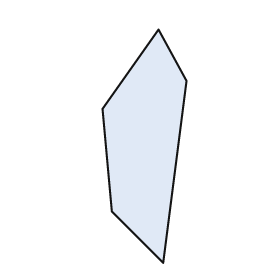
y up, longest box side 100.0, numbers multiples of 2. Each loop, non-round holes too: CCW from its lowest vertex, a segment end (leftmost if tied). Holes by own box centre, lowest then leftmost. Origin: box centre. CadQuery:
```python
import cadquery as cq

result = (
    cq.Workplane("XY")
    .moveTo(8.0, -50.0)
    .lineTo(18.0, 28.0)
    .lineTo(6.0, 50.0)
    .lineTo(-18.0, 16.0)
    .lineTo(-14.0, -28.0)
    .close()
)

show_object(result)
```